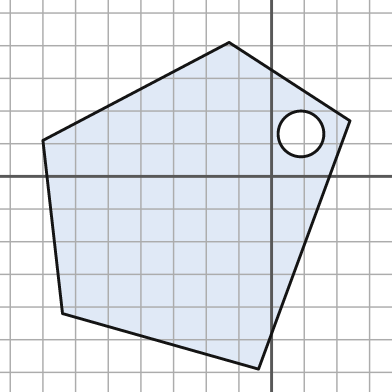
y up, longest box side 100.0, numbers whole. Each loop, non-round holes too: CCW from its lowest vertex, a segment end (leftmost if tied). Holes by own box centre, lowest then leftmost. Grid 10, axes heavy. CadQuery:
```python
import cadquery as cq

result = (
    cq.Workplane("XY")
    .moveTo(-4.0, -59.0)
    .lineTo(24.0, 17.0)
    .lineTo(-13.0, 41.0)
    .lineTo(-70.0, 11.0)
    .lineTo(-64.0, -42.0)
    .close()
    .moveTo(9.0, 13.0)
    .circle(7.0)
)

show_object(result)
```